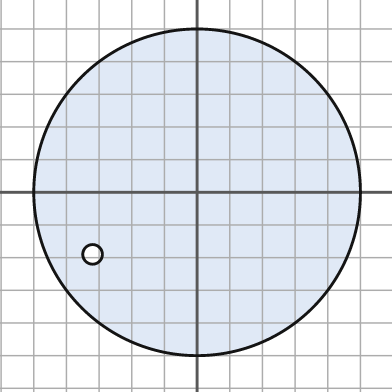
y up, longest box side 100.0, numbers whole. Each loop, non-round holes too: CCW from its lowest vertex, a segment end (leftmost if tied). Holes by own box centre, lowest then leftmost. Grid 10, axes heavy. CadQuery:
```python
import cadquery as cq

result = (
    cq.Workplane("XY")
    .moveTo(0.0, 0.0)
    .circle(50.0)
    .moveTo(-32.0, -19.0)
    .circle(3.0)
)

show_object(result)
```